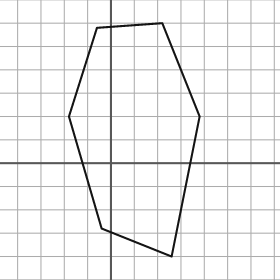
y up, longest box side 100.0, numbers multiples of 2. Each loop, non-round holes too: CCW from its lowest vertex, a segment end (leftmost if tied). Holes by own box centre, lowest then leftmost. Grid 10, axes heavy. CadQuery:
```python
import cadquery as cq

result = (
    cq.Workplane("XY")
    .moveTo(26.0, -40.0)
    .lineTo(38.0, 20.0)
    .lineTo(22.0, 60.0)
    .lineTo(-6.0, 58.0)
    .lineTo(-18.0, 20.0)
    .lineTo(-4.0, -28.0)
    .close()
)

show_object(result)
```